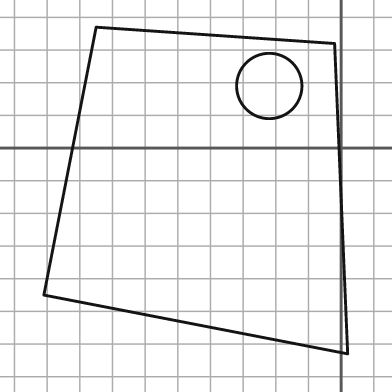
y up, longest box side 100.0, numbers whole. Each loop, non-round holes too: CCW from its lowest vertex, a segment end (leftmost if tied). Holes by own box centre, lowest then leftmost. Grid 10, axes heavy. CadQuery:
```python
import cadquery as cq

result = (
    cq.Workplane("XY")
    .moveTo(2.0, -63.0)
    .lineTo(-2.0, 32.0)
    .lineTo(-75.0, 37.0)
    .lineTo(-91.0, -45.0)
    .close()
    .moveTo(-22.0, 19.0)
    .circle(10.0)
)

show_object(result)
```